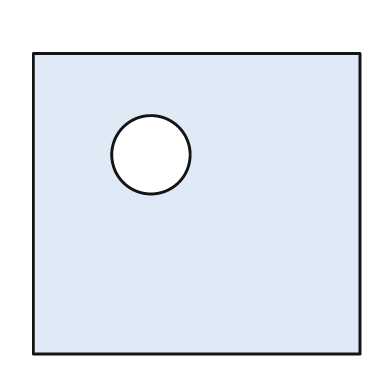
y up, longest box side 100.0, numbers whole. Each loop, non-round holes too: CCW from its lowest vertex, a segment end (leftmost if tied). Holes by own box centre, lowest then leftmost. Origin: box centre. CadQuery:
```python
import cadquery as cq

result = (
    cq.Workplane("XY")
    .moveTo(-50.0, -46.0)
    .lineTo(50.0, -46.0)
    .lineTo(50.0, 46.0)
    .lineTo(-50.0, 46.0)
    .close()
    .moveTo(-14.0, 15.0)
    .circle(12.0)
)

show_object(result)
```